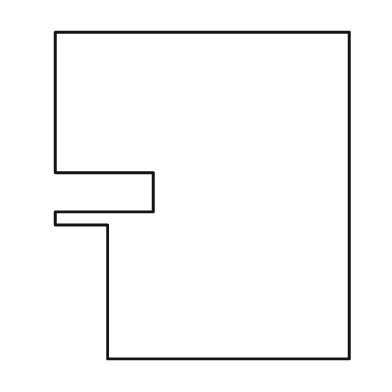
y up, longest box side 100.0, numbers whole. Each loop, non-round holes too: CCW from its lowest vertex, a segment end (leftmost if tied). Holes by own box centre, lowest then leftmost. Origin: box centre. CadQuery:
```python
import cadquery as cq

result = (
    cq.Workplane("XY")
    .moveTo(-29.0, -50.0)
    .lineTo(45.0, -50.0)
    .lineTo(45.0, 50.0)
    .lineTo(-45.0, 50.0)
    .lineTo(-45.0, 7.0)
    .lineTo(-15.0, 7.0)
    .lineTo(-15.0, -5.0)
    .lineTo(-45.0, -5.0)
    .lineTo(-45.0, -9.0)
    .lineTo(-29.0, -9.0)
    .close()
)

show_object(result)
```